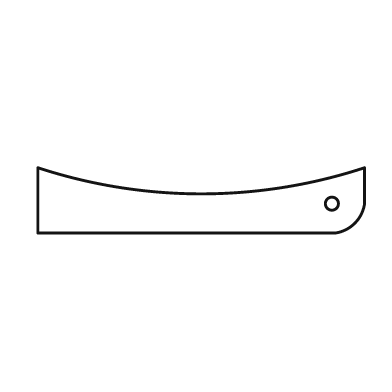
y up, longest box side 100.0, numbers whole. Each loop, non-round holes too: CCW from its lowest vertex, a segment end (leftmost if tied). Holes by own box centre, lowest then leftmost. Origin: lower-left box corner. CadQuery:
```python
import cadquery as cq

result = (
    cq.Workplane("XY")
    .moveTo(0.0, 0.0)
    .lineTo(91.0, 0.0)
    .threePointArc((97.0, 3.0), (100.0, 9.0))
    .lineTo(100.0, 20.0)
    .threePointArc((50.0, 12.0), (0.0, 20.0))
    .close()
    .moveTo(90.0, 9.0)
    .circle(2.0)
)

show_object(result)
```